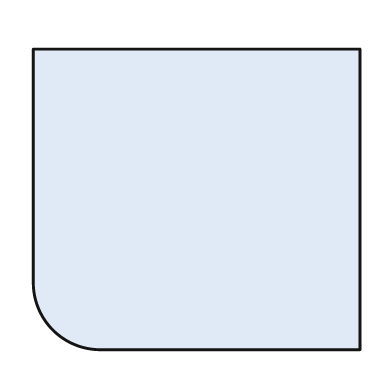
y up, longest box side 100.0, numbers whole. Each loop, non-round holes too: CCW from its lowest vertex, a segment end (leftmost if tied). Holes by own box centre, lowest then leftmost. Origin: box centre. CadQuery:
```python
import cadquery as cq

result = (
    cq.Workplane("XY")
    .moveTo(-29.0, -46.0)
    .lineTo(50.0, -46.0)
    .lineTo(50.0, 46.0)
    .lineTo(-50.0, 46.0)
    .lineTo(-50.0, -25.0)
    .threePointArc((-44.0, -40.0), (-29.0, -46.0))
    .close()
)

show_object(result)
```